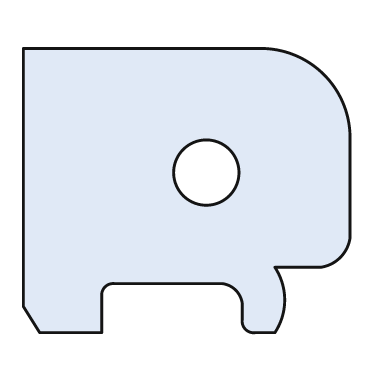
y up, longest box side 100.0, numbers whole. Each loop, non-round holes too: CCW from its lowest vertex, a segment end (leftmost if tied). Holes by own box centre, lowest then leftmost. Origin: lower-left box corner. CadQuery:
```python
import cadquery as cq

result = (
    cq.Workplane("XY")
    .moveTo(5.0, 0.0)
    .lineTo(24.0, 0.0)
    .lineTo(24.0, 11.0)
    .threePointArc((25.0, 14.0), (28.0, 15.0))
    .lineTo(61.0, 15.0)
    .threePointArc((65.0, 13.0), (67.0, 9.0))
    .lineTo(67.0, 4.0)
    .threePointArc((68.0, 1.0), (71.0, 0.0))
    .lineTo(77.0, 0.0)
    .threePointArc((80.0, 10.0), (77.0, 20.0))
    .lineTo(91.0, 20.0)
    .threePointArc((97.0, 23.0), (100.0, 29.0))
    .lineTo(100.0, 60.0)
    .threePointArc((92.0, 79.0), (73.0, 87.0))
    .lineTo(0.0, 87.0)
    .lineTo(0.0, 8.0)
    .close()
    .moveTo(56.0, 49.0)
    .circle(10.0)
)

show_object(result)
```